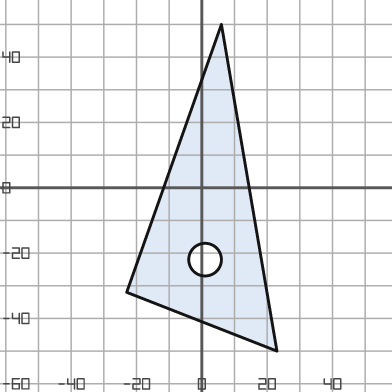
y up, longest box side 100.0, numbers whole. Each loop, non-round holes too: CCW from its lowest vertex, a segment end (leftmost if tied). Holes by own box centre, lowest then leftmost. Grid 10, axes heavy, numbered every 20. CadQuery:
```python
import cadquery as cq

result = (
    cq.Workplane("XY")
    .moveTo(23.0, -50.0)
    .lineTo(6.0, 50.0)
    .lineTo(-23.0, -32.0)
    .close()
    .moveTo(1.0, -22.0)
    .circle(5.0)
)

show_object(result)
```